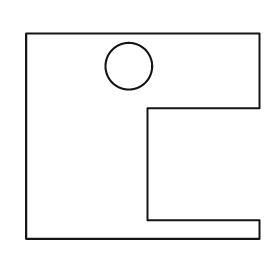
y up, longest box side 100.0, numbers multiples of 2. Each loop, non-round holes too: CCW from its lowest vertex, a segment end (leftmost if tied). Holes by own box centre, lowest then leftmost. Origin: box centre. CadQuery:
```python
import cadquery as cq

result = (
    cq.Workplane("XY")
    .moveTo(-50.0, -44.0)
    .lineTo(50.0, -44.0)
    .lineTo(50.0, -36.0)
    .lineTo(2.0, -36.0)
    .lineTo(2.0, 12.0)
    .lineTo(50.0, 12.0)
    .lineTo(50.0, 44.0)
    .lineTo(-50.0, 44.0)
    .close()
    .moveTo(-6.0, 30.0)
    .circle(10.0)
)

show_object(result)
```